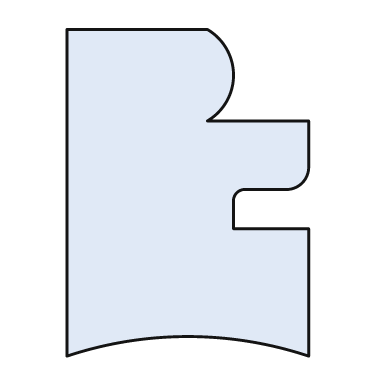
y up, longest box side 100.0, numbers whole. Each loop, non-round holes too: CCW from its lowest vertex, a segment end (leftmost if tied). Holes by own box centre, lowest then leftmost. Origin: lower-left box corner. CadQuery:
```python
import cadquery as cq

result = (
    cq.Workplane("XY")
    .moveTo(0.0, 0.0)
    .threePointArc((37.0, 6.0), (74.0, 0.0))
    .lineTo(74.0, 39.0)
    .lineTo(51.0, 39.0)
    .lineTo(51.0, 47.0)
    .threePointArc((52.0, 50.0), (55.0, 51.0))
    .lineTo(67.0, 51.0)
    .threePointArc((72.0, 53.0), (74.0, 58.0))
    .lineTo(74.0, 72.0)
    .lineTo(43.0, 72.0)
    .threePointArc((51.0, 86.0), (43.0, 100.0))
    .lineTo(0.0, 100.0)
    .close()
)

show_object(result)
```